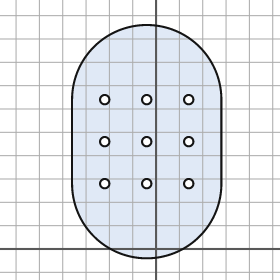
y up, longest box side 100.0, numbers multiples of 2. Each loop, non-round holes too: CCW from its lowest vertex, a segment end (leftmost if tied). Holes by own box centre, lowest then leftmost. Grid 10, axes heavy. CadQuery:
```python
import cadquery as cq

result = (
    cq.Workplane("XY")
    .moveTo(-36.0, 28.0)
    .threePointArc((-4.0, -4.0), (28.0, 28.0))
    .lineTo(28.0, 64.0)
    .threePointArc((-4.0, 96.0), (-36.0, 64.0))
    .close()
    .moveTo(-22.0, 28.0)
    .circle(2.0)
    .moveTo(-4.0, 28.0)
    .circle(2.0)
    .moveTo(14.0, 28.0)
    .circle(2.0)
    .moveTo(-22.0, 46.0)
    .circle(2.0)
    .moveTo(-4.0, 46.0)
    .circle(2.0)
    .moveTo(14.0, 46.0)
    .circle(2.0)
    .moveTo(-22.0, 64.0)
    .circle(2.0)
    .moveTo(-4.0, 64.0)
    .circle(2.0)
    .moveTo(14.0, 64.0)
    .circle(2.0)
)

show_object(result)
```